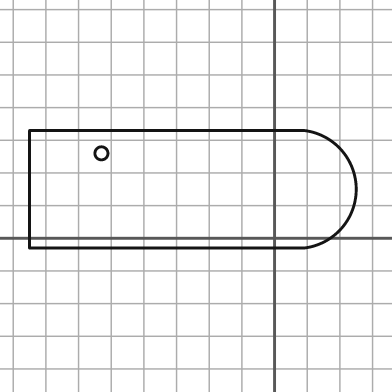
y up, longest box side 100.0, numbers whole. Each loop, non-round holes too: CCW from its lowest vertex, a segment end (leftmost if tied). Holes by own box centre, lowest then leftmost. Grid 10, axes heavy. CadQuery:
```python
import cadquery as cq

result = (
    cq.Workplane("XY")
    .moveTo(-75.0, -3.0)
    .lineTo(9.0, -3.0)
    .threePointArc((25.0, 15.0), (9.0, 33.0))
    .lineTo(-75.0, 33.0)
    .close()
    .moveTo(-53.0, 26.0)
    .circle(2.0)
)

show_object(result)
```